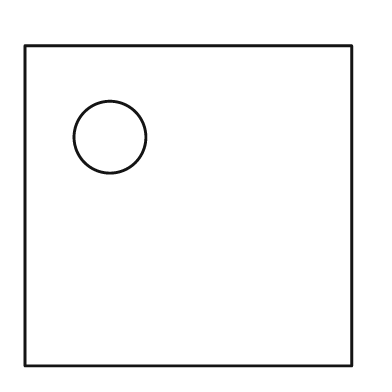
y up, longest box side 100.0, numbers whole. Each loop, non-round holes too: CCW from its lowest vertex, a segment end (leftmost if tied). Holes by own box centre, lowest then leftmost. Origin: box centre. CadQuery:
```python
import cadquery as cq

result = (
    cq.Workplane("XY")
    .moveTo(-50.0, -49.0)
    .lineTo(50.0, -49.0)
    .lineTo(50.0, 49.0)
    .lineTo(-50.0, 49.0)
    .close()
    .moveTo(-24.0, 21.0)
    .circle(11.0)
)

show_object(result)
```